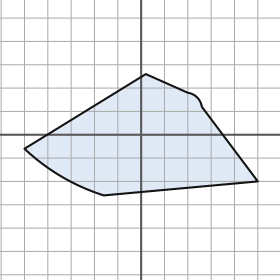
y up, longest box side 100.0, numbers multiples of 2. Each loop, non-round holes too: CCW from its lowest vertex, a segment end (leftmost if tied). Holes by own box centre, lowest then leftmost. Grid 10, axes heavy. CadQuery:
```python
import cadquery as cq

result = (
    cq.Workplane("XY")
    .moveTo(-16.0, -26.0)
    .lineTo(50.0, -20.0)
    .lineTo(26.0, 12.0)
    .threePointArc((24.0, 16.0), (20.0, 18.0))
    .lineTo(2.0, 26.0)
    .lineTo(-50.0, -6.0)
    .threePointArc((-34.0, -18.0), (-16.0, -26.0))
    .close()
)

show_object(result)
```